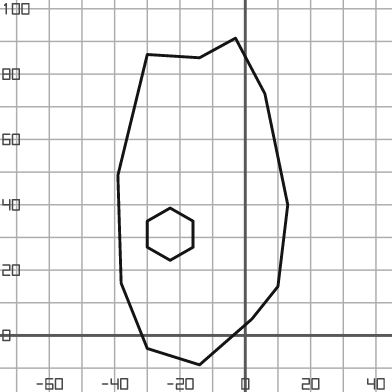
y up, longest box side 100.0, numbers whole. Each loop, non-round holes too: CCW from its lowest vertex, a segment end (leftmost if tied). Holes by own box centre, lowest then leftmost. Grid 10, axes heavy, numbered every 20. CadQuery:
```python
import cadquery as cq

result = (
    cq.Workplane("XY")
    .moveTo(-14.0, -9.0)
    .lineTo(2.0, 5.0)
    .lineTo(10.0, 15.0)
    .lineTo(13.0, 40.0)
    .lineTo(6.0, 74.0)
    .lineTo(-3.0, 91.0)
    .lineTo(-14.0, 85.0)
    .lineTo(-30.0, 86.0)
    .lineTo(-39.0, 49.0)
    .lineTo(-38.0, 16.0)
    .lineTo(-30.0, -4.0)
    .close()
    .moveTo(-23.0, 23.0)
    .lineTo(-16.0, 27.0)
    .lineTo(-16.0, 35.0)
    .lineTo(-23.0, 39.0)
    .lineTo(-30.0, 35.0)
    .lineTo(-30.0, 27.0)
    .close()
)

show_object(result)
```